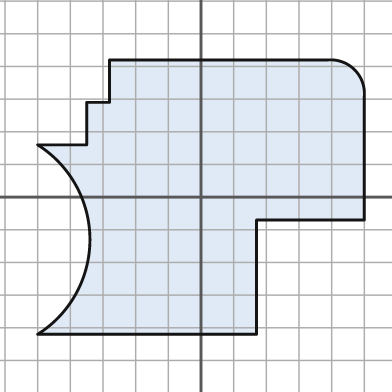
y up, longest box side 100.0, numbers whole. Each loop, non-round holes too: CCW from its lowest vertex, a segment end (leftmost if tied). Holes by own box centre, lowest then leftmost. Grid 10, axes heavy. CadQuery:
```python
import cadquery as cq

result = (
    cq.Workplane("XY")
    .moveTo(-50.0, -42.0)
    .lineTo(17.0, -42.0)
    .lineTo(17.0, -7.0)
    .lineTo(50.0, -7.0)
    .lineTo(50.0, 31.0)
    .threePointArc((47.0, 39.0), (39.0, 42.0))
    .lineTo(-28.0, 42.0)
    .lineTo(-28.0, 29.0)
    .lineTo(-35.0, 29.0)
    .lineTo(-35.0, 16.0)
    .lineTo(-50.0, 16.0)
    .threePointArc((-34.0, -13.0), (-50.0, -42.0))
    .close()
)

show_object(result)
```